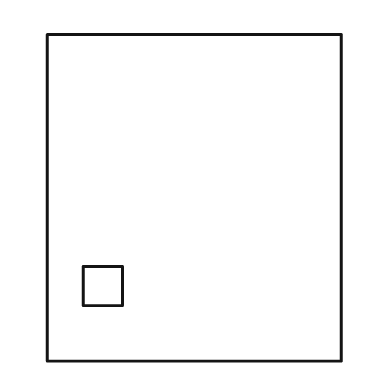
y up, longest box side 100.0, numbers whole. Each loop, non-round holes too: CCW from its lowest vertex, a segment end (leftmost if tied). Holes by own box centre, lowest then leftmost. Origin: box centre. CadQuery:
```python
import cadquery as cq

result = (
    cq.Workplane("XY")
    .moveTo(-45.0, -50.0)
    .lineTo(45.0, -50.0)
    .lineTo(45.0, 50.0)
    .lineTo(-45.0, 50.0)
    .close()
    .moveTo(-34.0, -33.0)
    .lineTo(-22.0, -33.0)
    .lineTo(-22.0, -21.0)
    .lineTo(-34.0, -21.0)
    .close()
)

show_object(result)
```